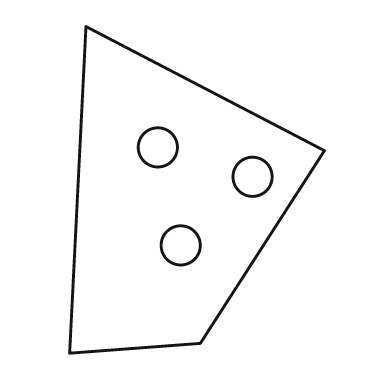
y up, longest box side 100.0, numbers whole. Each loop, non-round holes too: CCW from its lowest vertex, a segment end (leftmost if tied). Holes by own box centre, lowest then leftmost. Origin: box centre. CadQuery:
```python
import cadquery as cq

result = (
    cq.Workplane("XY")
    .moveTo(-39.0, -50.0)
    .lineTo(1.0, -47.0)
    .lineTo(39.0, 12.0)
    .lineTo(-34.0, 50.0)
    .close()
    .moveTo(-5.0, -17.0)
    .circle(6.0)
    .moveTo(17.0, 4.0)
    .circle(6.0)
    .moveTo(-12.0, 13.0)
    .circle(6.0)
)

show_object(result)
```